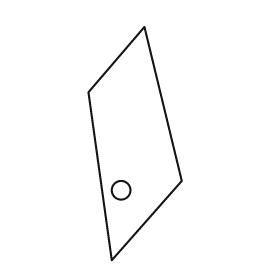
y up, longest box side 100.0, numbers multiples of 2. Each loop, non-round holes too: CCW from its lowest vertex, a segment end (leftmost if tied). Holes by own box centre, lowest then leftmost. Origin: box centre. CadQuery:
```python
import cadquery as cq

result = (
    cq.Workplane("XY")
    .moveTo(-10.0, -50.0)
    .lineTo(20.0, -16.0)
    .lineTo(4.0, 50.0)
    .lineTo(-20.0, 22.0)
    .close()
    .moveTo(-6.0, -20.0)
    .circle(4.0)
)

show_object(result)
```